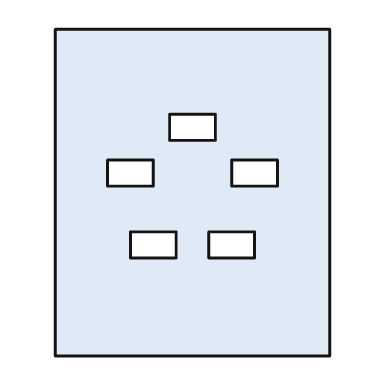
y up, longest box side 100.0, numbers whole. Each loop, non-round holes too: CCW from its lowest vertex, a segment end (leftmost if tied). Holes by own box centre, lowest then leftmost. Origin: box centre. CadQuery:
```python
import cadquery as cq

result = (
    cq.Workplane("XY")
    .moveTo(-42.0, -50.0)
    .lineTo(42.0, -50.0)
    .lineTo(42.0, 50.0)
    .lineTo(-42.0, 50.0)
    .close()
    .moveTo(-19.0, -20.0)
    .lineTo(-5.0, -20.0)
    .lineTo(-5.0, -12.0)
    .lineTo(-19.0, -12.0)
    .close()
    .moveTo(5.0, -20.0)
    .lineTo(19.0, -20.0)
    .lineTo(19.0, -12.0)
    .lineTo(5.0, -12.0)
    .close()
    .moveTo(-26.0, 2.0)
    .lineTo(-12.0, 2.0)
    .lineTo(-12.0, 10.0)
    .lineTo(-26.0, 10.0)
    .close()
    .moveTo(12.0, 2.0)
    .lineTo(26.0, 2.0)
    .lineTo(26.0, 10.0)
    .lineTo(12.0, 10.0)
    .close()
    .moveTo(-7.0, 16.0)
    .lineTo(7.0, 16.0)
    .lineTo(7.0, 24.0)
    .lineTo(-7.0, 24.0)
    .close()
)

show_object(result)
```